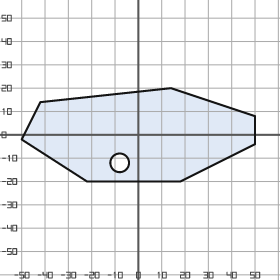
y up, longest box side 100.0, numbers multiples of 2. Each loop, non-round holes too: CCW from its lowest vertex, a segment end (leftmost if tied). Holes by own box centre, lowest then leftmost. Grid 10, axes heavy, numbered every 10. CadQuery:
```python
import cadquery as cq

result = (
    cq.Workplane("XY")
    .moveTo(-22.0, -20.0)
    .lineTo(18.0, -20.0)
    .lineTo(50.0, -4.0)
    .lineTo(50.0, 8.0)
    .lineTo(14.0, 20.0)
    .lineTo(-42.0, 14.0)
    .lineTo(-50.0, -2.0)
    .close()
    .moveTo(-8.0, -12.0)
    .circle(4.0)
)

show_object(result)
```